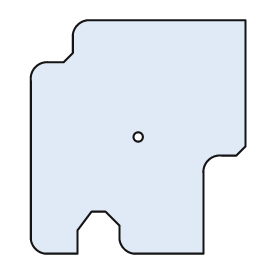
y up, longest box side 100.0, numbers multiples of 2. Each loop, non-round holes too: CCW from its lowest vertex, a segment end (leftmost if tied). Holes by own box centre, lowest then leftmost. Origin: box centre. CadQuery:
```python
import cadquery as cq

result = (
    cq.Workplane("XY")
    .moveTo(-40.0, -50.0)
    .lineTo(-26.0, -50.0)
    .lineTo(-26.0, -40.0)
    .lineTo(-20.0, -32.0)
    .lineTo(-14.0, -32.0)
    .lineTo(-8.0, -38.0)
    .lineTo(-8.0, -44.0)
    .threePointArc((-6.0, -48.0), (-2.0, -50.0))
    .lineTo(28.0, -50.0)
    .lineTo(28.0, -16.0)
    .threePointArc((30.0, -10.0), (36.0, -8.0))
    .lineTo(42.0, -8.0)
    .lineTo(46.0, -4.0)
    .lineTo(46.0, 50.0)
    .lineTo(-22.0, 50.0)
    .threePointArc((-26.0, 48.0), (-28.0, 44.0))
    .lineTo(-28.0, 36.0)
    .lineTo(-32.0, 32.0)
    .lineTo(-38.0, 32.0)
    .threePointArc((-44.0, 30.0), (-46.0, 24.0))
    .lineTo(-46.0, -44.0)
    .threePointArc((-44.0, -48.0), (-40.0, -50.0))
    .close()
    .moveTo(0.0, 0.0)
    .circle(2.0)
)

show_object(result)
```